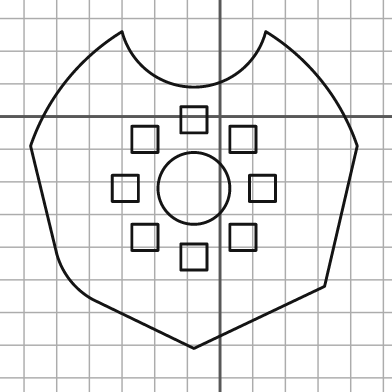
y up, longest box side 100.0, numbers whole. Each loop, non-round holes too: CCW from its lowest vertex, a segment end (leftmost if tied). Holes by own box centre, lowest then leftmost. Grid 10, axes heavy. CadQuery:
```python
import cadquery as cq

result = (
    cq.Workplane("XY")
    .moveTo(-8.0, -71.0)
    .lineTo(32.0, -52.0)
    .lineTo(42.0, -9.0)
    .threePointArc((31.0, 11.0), (14.0, 26.0))
    .threePointArc((-8.0, 9.0), (-30.0, 26.0))
    .threePointArc((-47.0, 11.0), (-58.0, -9.0))
    .lineTo(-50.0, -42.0)
    .threePointArc((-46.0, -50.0), (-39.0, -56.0))
    .close()
    .moveTo(-12.0, -47.0)
    .lineTo(-4.0, -47.0)
    .lineTo(-4.0, -39.0)
    .lineTo(-12.0, -39.0)
    .close()
    .moveTo(-27.0, -41.0)
    .lineTo(-19.0, -41.0)
    .lineTo(-19.0, -33.0)
    .lineTo(-27.0, -33.0)
    .close()
    .moveTo(3.0, -41.0)
    .lineTo(11.0, -41.0)
    .lineTo(11.0, -33.0)
    .lineTo(3.0, -33.0)
    .close()
    .moveTo(-33.0, -26.0)
    .lineTo(-25.0, -26.0)
    .lineTo(-25.0, -18.0)
    .lineTo(-33.0, -18.0)
    .close()
    .moveTo(-8.0, -22.0)
    .circle(11.0)
    .moveTo(9.0, -26.0)
    .lineTo(17.0, -26.0)
    .lineTo(17.0, -18.0)
    .lineTo(9.0, -18.0)
    .close()
    .moveTo(-27.0, -11.0)
    .lineTo(-19.0, -11.0)
    .lineTo(-19.0, -3.0)
    .lineTo(-27.0, -3.0)
    .close()
    .moveTo(3.0, -11.0)
    .lineTo(11.0, -11.0)
    .lineTo(11.0, -3.0)
    .lineTo(3.0, -3.0)
    .close()
    .moveTo(-12.0, -5.0)
    .lineTo(-4.0, -5.0)
    .lineTo(-4.0, 3.0)
    .lineTo(-12.0, 3.0)
    .close()
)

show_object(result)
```